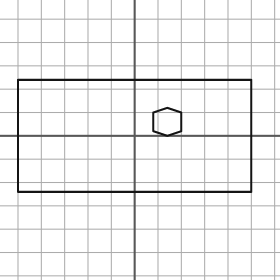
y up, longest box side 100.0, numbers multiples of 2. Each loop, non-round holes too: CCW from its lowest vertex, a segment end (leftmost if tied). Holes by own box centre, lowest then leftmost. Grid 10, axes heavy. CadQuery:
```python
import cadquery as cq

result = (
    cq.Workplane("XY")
    .moveTo(-50.0, -24.0)
    .lineTo(50.0, -24.0)
    .lineTo(50.0, 24.0)
    .lineTo(-50.0, 24.0)
    .close()
    .moveTo(14.0, 0.0)
    .lineTo(20.0, 2.0)
    .lineTo(20.0, 10.0)
    .lineTo(14.0, 12.0)
    .lineTo(8.0, 10.0)
    .lineTo(8.0, 2.0)
    .close()
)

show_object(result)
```